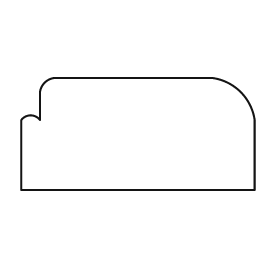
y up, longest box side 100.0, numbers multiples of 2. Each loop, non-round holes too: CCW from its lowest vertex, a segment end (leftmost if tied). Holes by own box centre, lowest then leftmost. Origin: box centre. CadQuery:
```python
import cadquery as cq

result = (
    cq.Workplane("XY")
    .moveTo(-50.0, -24.0)
    .lineTo(50.0, -24.0)
    .lineTo(50.0, 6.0)
    .threePointArc((44.0, 18.0), (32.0, 24.0))
    .lineTo(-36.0, 24.0)
    .threePointArc((-40.0, 22.0), (-42.0, 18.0))
    .lineTo(-42.0, 6.0)
    .threePointArc((-46.0, 8.0), (-50.0, 6.0))
    .close()
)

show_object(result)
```